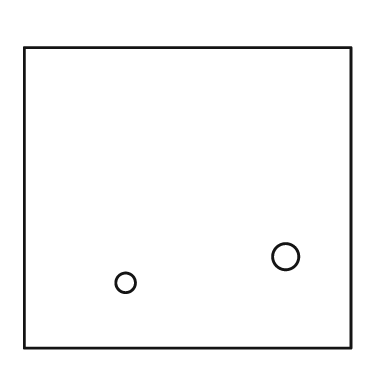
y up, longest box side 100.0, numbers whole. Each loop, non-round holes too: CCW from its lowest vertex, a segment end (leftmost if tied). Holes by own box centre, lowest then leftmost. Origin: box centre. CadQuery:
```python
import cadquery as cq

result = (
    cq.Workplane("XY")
    .moveTo(-50.0, -46.0)
    .lineTo(50.0, -46.0)
    .lineTo(50.0, 46.0)
    .lineTo(-50.0, 46.0)
    .close()
    .moveTo(-19.0, -26.0)
    .circle(3.0)
    .moveTo(30.0, -18.0)
    .circle(4.0)
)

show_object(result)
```